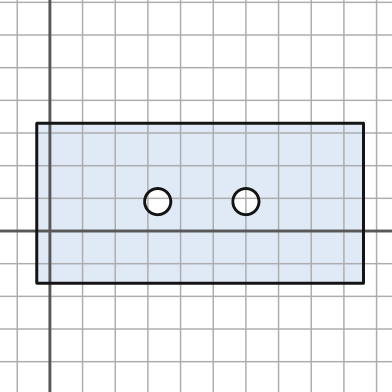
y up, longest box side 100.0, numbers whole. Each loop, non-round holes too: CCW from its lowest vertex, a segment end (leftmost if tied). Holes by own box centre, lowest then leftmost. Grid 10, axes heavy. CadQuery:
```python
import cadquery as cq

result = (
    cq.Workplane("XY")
    .moveTo(-4.0, -16.0)
    .lineTo(96.0, -16.0)
    .lineTo(96.0, 33.0)
    .lineTo(-4.0, 33.0)
    .close()
    .moveTo(33.0, 9.0)
    .circle(4.0)
    .moveTo(60.0, 9.0)
    .circle(4.0)
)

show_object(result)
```